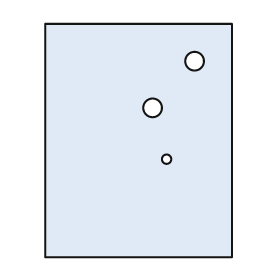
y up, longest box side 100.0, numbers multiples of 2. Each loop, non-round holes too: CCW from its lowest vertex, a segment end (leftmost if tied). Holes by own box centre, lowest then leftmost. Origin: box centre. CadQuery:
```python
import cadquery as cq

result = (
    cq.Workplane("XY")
    .moveTo(-40.0, -50.0)
    .lineTo(40.0, -50.0)
    .lineTo(40.0, 50.0)
    .lineTo(-40.0, 50.0)
    .close()
    .moveTo(12.0, -8.0)
    .circle(2.0)
    .moveTo(6.0, 14.0)
    .circle(4.0)
    .moveTo(24.0, 34.0)
    .circle(4.0)
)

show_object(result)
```